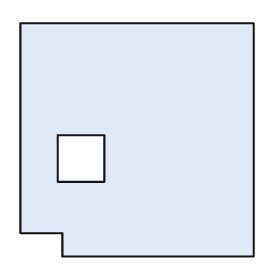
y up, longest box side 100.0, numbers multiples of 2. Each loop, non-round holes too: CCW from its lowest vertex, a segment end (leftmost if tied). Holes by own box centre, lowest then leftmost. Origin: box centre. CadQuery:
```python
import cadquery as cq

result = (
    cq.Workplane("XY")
    .moveTo(-32.0, -50.0)
    .lineTo(50.0, -50.0)
    .lineTo(50.0, 50.0)
    .lineTo(-50.0, 50.0)
    .lineTo(-50.0, -40.0)
    .lineTo(-32.0, -40.0)
    .close()
    .moveTo(-34.0, -18.0)
    .lineTo(-14.0, -18.0)
    .lineTo(-14.0, 2.0)
    .lineTo(-34.0, 2.0)
    .close()
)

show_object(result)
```